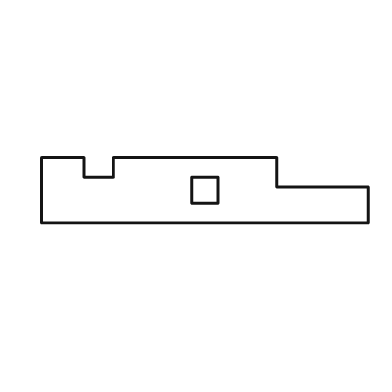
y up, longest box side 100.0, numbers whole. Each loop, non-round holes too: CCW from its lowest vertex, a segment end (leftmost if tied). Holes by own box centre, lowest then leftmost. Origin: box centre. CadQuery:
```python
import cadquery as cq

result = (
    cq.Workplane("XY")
    .moveTo(-50.0, -10.0)
    .lineTo(50.0, -10.0)
    .lineTo(50.0, 1.0)
    .lineTo(22.0, 1.0)
    .lineTo(22.0, 10.0)
    .lineTo(-28.0, 10.0)
    .lineTo(-28.0, 4.0)
    .lineTo(-37.0, 4.0)
    .lineTo(-37.0, 10.0)
    .lineTo(-50.0, 10.0)
    .close()
    .moveTo(-4.0, -4.0)
    .lineTo(4.0, -4.0)
    .lineTo(4.0, 4.0)
    .lineTo(-4.0, 4.0)
    .close()
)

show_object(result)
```